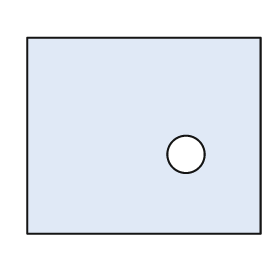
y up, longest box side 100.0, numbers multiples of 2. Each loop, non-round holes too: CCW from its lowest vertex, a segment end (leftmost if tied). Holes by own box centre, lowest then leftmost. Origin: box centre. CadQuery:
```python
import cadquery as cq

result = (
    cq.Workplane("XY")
    .moveTo(-50.0, -42.0)
    .lineTo(50.0, -42.0)
    .lineTo(50.0, 42.0)
    .lineTo(-50.0, 42.0)
    .close()
    .moveTo(18.0, -8.0)
    .circle(8.0)
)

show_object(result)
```